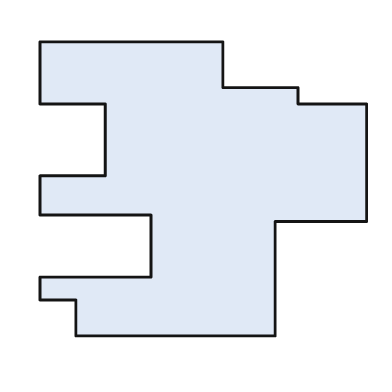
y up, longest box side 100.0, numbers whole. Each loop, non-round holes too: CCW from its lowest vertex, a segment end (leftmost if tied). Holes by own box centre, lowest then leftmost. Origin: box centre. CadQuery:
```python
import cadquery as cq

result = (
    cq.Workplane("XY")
    .moveTo(-39.0, -45.0)
    .lineTo(22.0, -45.0)
    .lineTo(22.0, -10.0)
    .lineTo(50.0, -10.0)
    .lineTo(50.0, 26.0)
    .lineTo(29.0, 26.0)
    .lineTo(29.0, 31.0)
    .lineTo(6.0, 31.0)
    .lineTo(6.0, 45.0)
    .lineTo(-50.0, 45.0)
    .lineTo(-50.0, 26.0)
    .lineTo(-30.0, 26.0)
    .lineTo(-30.0, 4.0)
    .lineTo(-50.0, 4.0)
    .lineTo(-50.0, -8.0)
    .lineTo(-16.0, -8.0)
    .lineTo(-16.0, -27.0)
    .lineTo(-50.0, -27.0)
    .lineTo(-50.0, -34.0)
    .lineTo(-39.0, -34.0)
    .close()
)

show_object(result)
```